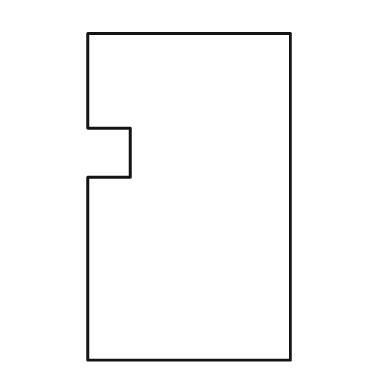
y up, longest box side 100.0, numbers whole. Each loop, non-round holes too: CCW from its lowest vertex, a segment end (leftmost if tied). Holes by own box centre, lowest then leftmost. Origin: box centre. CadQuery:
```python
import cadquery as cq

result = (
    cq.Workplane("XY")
    .moveTo(-31.0, -50.0)
    .lineTo(31.0, -50.0)
    .lineTo(31.0, 50.0)
    .lineTo(-31.0, 50.0)
    .lineTo(-31.0, 21.0)
    .lineTo(-18.0, 21.0)
    .lineTo(-18.0, 6.0)
    .lineTo(-31.0, 6.0)
    .close()
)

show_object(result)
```